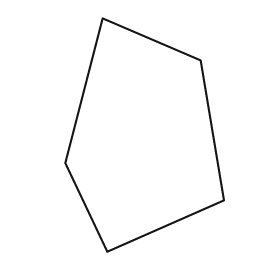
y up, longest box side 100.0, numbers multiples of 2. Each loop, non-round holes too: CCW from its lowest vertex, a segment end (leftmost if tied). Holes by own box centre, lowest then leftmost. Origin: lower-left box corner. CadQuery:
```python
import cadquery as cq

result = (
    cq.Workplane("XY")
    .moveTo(18.0, 0.0)
    .lineTo(68.0, 22.0)
    .lineTo(58.0, 82.0)
    .lineTo(16.0, 100.0)
    .lineTo(0.0, 38.0)
    .close()
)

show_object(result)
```